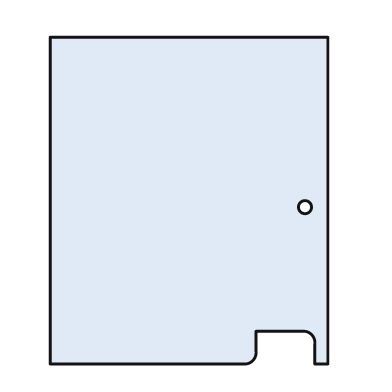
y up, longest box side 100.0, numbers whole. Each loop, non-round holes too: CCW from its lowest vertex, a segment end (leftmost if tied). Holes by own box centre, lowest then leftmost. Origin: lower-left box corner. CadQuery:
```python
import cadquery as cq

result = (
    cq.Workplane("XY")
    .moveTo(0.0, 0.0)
    .lineTo(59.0, 0.0)
    .threePointArc((62.0, 1.0), (63.0, 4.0))
    .lineTo(63.0, 10.0)
    .lineTo(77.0, 10.0)
    .threePointArc((80.0, 9.0), (81.0, 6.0))
    .lineTo(81.0, 0.0)
    .lineTo(85.0, 0.0)
    .lineTo(85.0, 100.0)
    .lineTo(0.0, 100.0)
    .close()
    .moveTo(78.0, 48.0)
    .circle(2.0)
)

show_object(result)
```